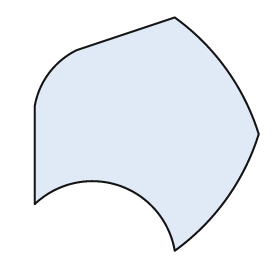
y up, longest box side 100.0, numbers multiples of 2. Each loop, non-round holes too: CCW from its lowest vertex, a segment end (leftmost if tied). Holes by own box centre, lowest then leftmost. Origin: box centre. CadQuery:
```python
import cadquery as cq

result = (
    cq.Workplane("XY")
    .moveTo(12.0, -50.0)
    .threePointArc((34.0, -28.0), (48.0, 0.0))
    .threePointArc((34.0, 28.0), (12.0, 50.0))
    .lineTo(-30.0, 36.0)
    .threePointArc((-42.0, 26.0), (-48.0, 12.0))
    .lineTo(-48.0, -30.0)
    .threePointArc((-12.0, -22.0), (12.0, -50.0))
    .close()
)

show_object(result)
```